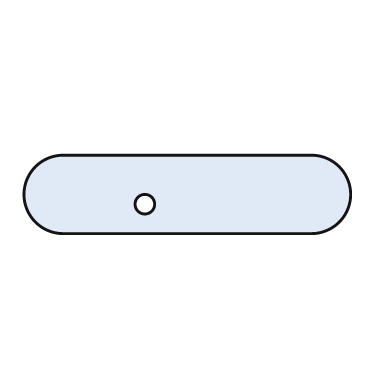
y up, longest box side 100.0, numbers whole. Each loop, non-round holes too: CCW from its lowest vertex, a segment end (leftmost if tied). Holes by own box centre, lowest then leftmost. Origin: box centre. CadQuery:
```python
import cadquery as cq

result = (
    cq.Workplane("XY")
    .moveTo(-38.0, -12.0)
    .lineTo(38.0, -12.0)
    .threePointArc((50.0, 0.0), (38.0, 12.0))
    .lineTo(-38.0, 12.0)
    .threePointArc((-50.0, 0.0), (-38.0, -12.0))
    .close()
    .moveTo(-13.0, -3.0)
    .circle(3.0)
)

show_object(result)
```